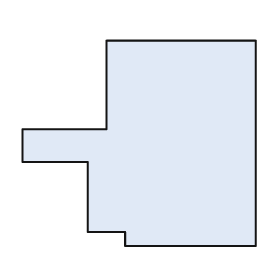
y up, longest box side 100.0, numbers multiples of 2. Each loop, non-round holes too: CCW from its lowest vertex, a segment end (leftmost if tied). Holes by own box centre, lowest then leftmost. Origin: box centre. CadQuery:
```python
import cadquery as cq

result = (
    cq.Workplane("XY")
    .moveTo(-6.0, -44.0)
    .lineTo(50.0, -44.0)
    .lineTo(50.0, 44.0)
    .lineTo(-14.0, 44.0)
    .lineTo(-14.0, 6.0)
    .lineTo(-50.0, 6.0)
    .lineTo(-50.0, -8.0)
    .lineTo(-22.0, -8.0)
    .lineTo(-22.0, -38.0)
    .lineTo(-6.0, -38.0)
    .close()
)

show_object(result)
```